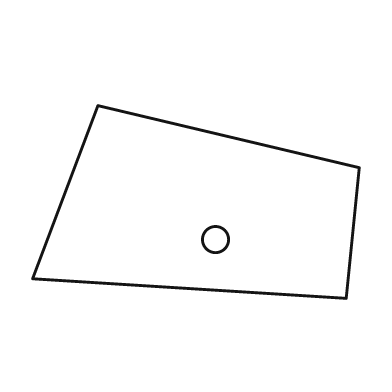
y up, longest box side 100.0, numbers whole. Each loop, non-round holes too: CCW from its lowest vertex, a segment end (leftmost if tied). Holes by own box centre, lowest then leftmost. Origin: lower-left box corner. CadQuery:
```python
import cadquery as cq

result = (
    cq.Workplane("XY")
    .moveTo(96.0, 0.0)
    .lineTo(100.0, 40.0)
    .lineTo(20.0, 59.0)
    .lineTo(0.0, 6.0)
    .close()
    .moveTo(56.0, 18.0)
    .circle(4.0)
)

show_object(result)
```